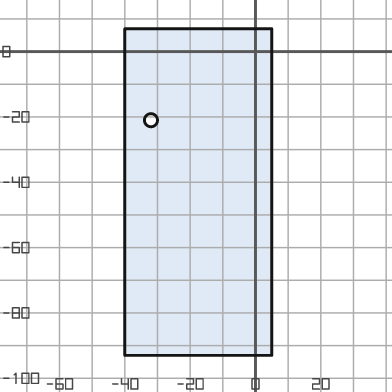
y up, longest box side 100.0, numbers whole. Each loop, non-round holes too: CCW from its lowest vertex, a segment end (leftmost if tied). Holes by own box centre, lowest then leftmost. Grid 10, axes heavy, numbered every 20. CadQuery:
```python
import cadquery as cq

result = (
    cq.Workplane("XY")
    .moveTo(-40.0, -93.0)
    .lineTo(5.0, -93.0)
    .lineTo(5.0, 7.0)
    .lineTo(-40.0, 7.0)
    .close()
    .moveTo(-32.0, -21.0)
    .circle(2.0)
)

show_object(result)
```